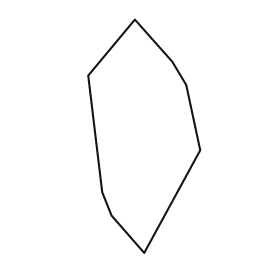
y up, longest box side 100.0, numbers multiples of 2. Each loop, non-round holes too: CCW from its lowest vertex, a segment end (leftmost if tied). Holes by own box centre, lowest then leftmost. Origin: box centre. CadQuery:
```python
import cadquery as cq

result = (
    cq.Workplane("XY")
    .moveTo(0.0, -50.0)
    .lineTo(24.0, -6.0)
    .lineTo(18.0, 22.0)
    .lineTo(12.0, 32.0)
    .lineTo(-4.0, 50.0)
    .lineTo(-24.0, 26.0)
    .lineTo(-18.0, -24.0)
    .lineTo(-14.0, -34.0)
    .close()
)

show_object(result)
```